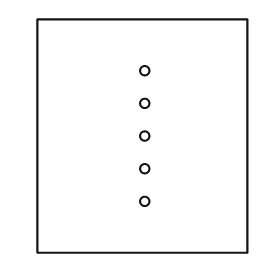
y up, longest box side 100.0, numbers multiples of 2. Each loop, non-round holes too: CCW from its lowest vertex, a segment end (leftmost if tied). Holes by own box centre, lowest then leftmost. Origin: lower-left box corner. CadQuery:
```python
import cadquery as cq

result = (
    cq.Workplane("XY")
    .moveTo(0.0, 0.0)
    .lineTo(90.0, 0.0)
    .lineTo(90.0, 100.0)
    .lineTo(0.0, 100.0)
    .close()
    .moveTo(46.0, 22.0)
    .circle(2.0)
    .moveTo(46.0, 36.0)
    .circle(2.0)
    .moveTo(46.0, 50.0)
    .circle(2.0)
    .moveTo(46.0, 64.0)
    .circle(2.0)
    .moveTo(46.0, 78.0)
    .circle(2.0)
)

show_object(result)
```